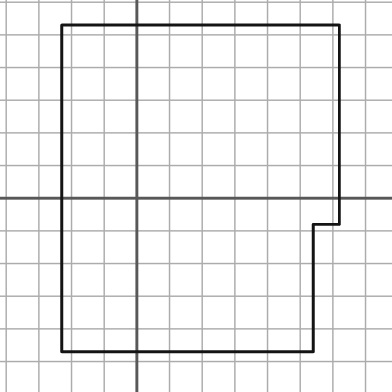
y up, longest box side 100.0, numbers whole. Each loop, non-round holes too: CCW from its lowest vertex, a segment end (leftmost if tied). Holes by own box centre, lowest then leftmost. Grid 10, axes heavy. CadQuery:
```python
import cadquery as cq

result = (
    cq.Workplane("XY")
    .moveTo(-23.0, -47.0)
    .lineTo(54.0, -47.0)
    .lineTo(54.0, -8.0)
    .lineTo(62.0, -8.0)
    .lineTo(62.0, 53.0)
    .lineTo(-23.0, 53.0)
    .close()
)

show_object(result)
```